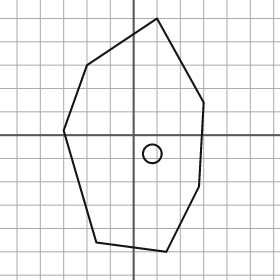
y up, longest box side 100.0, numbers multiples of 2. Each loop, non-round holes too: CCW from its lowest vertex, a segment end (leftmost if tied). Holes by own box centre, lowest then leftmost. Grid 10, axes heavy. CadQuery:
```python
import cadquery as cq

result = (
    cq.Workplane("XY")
    .moveTo(14.0, -50.0)
    .lineTo(28.0, -22.0)
    .lineTo(30.0, 14.0)
    .lineTo(10.0, 50.0)
    .lineTo(-20.0, 30.0)
    .lineTo(-30.0, 2.0)
    .lineTo(-16.0, -46.0)
    .close()
    .moveTo(8.0, -8.0)
    .circle(4.0)
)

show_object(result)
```